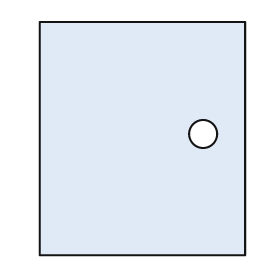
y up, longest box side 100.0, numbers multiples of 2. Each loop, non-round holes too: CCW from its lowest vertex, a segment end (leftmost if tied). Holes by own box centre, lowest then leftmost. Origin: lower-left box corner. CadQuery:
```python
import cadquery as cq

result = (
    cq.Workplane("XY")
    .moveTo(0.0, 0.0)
    .lineTo(88.0, 0.0)
    .lineTo(88.0, 100.0)
    .lineTo(0.0, 100.0)
    .close()
    .moveTo(70.0, 52.0)
    .circle(6.0)
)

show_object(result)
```